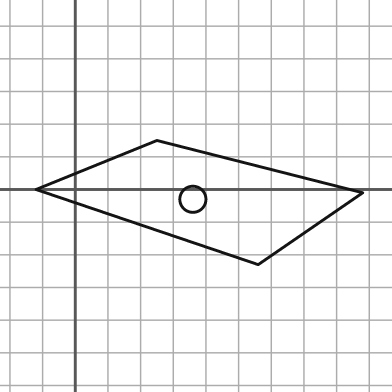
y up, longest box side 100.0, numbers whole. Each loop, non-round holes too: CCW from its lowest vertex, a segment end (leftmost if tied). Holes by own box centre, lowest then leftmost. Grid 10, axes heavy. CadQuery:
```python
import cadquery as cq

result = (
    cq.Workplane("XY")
    .moveTo(56.0, -23.0)
    .lineTo(88.0, -1.0)
    .lineTo(25.0, 15.0)
    .lineTo(-12.0, 0.0)
    .close()
    .moveTo(36.0, -3.0)
    .circle(4.0)
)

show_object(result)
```